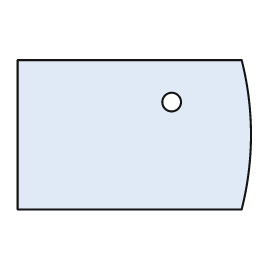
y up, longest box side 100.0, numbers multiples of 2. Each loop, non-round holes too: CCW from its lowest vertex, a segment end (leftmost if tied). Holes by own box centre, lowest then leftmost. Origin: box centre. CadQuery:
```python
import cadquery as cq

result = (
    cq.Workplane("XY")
    .moveTo(-50.0, -32.0)
    .lineTo(46.0, -32.0)
    .threePointArc((50.0, 0.0), (46.0, 32.0))
    .lineTo(-50.0, 32.0)
    .close()
    .moveTo(16.0, 14.0)
    .circle(4.0)
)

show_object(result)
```